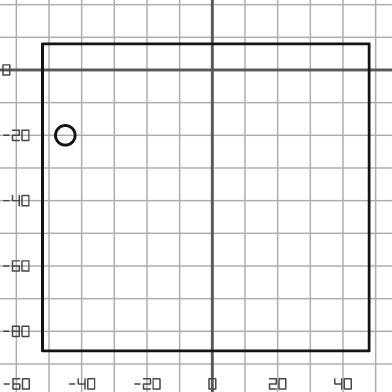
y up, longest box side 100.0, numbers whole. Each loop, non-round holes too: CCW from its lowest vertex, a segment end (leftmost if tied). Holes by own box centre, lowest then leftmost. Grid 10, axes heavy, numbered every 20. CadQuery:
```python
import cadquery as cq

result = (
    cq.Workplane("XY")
    .moveTo(-52.0, -86.0)
    .lineTo(48.0, -86.0)
    .lineTo(48.0, 8.0)
    .lineTo(-52.0, 8.0)
    .close()
    .moveTo(-45.0, -20.0)
    .circle(3.0)
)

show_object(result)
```